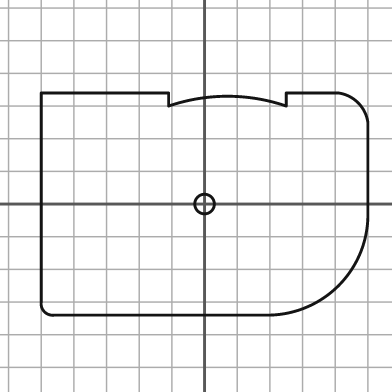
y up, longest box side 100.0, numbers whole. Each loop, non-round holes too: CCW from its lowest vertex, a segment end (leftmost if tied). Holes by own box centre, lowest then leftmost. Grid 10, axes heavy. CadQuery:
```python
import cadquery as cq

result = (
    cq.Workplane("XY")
    .moveTo(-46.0, -34.0)
    .lineTo(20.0, -34.0)
    .threePointArc((41.0, -25.0), (50.0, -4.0))
    .lineTo(50.0, 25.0)
    .threePointArc((47.0, 31.0), (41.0, 34.0))
    .lineTo(25.0, 34.0)
    .lineTo(25.0, 30.0)
    .threePointArc((7.0, 33.0), (-11.0, 30.0))
    .lineTo(-11.0, 34.0)
    .lineTo(-50.0, 34.0)
    .lineTo(-50.0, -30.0)
    .threePointArc((-49.0, -33.0), (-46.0, -34.0))
    .close()
    .moveTo(0.0, 0.0)
    .circle(3.0)
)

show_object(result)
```